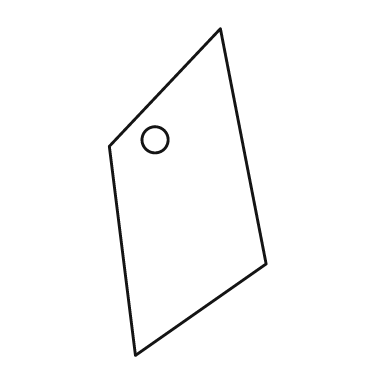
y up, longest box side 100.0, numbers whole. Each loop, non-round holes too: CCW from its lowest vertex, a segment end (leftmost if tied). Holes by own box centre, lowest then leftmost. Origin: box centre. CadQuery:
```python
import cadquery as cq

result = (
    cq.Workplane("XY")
    .moveTo(-16.0, -50.0)
    .lineTo(24.0, -22.0)
    .lineTo(10.0, 50.0)
    .lineTo(-24.0, 14.0)
    .close()
    .moveTo(-10.0, 16.0)
    .circle(4.0)
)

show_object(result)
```